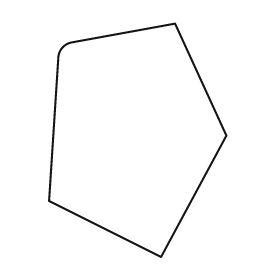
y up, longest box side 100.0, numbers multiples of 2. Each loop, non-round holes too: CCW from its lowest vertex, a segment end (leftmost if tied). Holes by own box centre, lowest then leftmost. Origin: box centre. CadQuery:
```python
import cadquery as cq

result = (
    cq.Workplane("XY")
    .moveTo(10.0, -50.0)
    .lineTo(38.0, 2.0)
    .lineTo(16.0, 50.0)
    .lineTo(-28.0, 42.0)
    .threePointArc((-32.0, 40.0), (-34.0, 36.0))
    .lineTo(-38.0, -26.0)
    .close()
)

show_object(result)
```